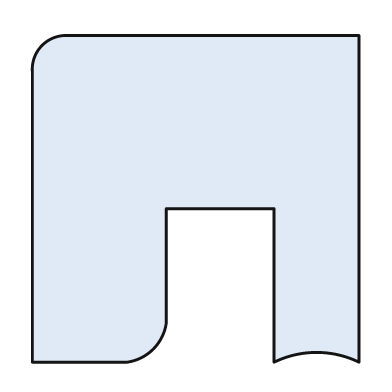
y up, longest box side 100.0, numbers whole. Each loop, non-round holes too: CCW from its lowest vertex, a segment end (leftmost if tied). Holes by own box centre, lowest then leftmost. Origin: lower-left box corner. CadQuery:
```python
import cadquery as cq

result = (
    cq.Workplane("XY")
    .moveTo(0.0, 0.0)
    .lineTo(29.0, 0.0)
    .threePointArc((37.0, 4.0), (41.0, 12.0))
    .lineTo(41.0, 47.0)
    .lineTo(74.0, 47.0)
    .lineTo(74.0, 0.0)
    .threePointArc((87.0, 3.0), (100.0, 0.0))
    .lineTo(100.0, 100.0)
    .lineTo(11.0, 100.0)
    .threePointArc((3.0, 97.0), (0.0, 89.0))
    .close()
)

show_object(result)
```